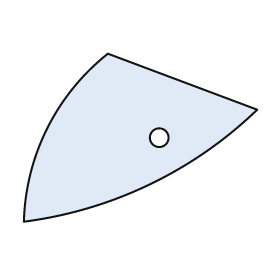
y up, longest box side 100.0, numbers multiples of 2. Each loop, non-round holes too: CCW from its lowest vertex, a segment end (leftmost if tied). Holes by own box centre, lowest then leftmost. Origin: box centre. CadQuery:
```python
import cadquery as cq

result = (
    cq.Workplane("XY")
    .moveTo(-50.0, -36.0)
    .threePointArc((4.0, -20.0), (50.0, 12.0))
    .lineTo(-14.0, 36.0)
    .threePointArc((-40.0, 4.0), (-50.0, -36.0))
    .close()
    .moveTo(8.0, 0.0)
    .circle(4.0)
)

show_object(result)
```